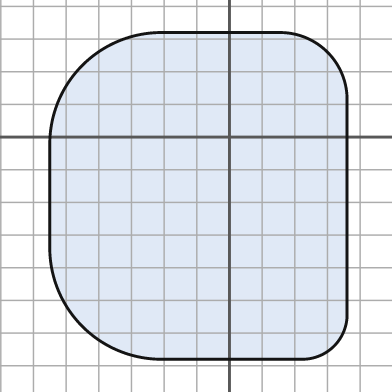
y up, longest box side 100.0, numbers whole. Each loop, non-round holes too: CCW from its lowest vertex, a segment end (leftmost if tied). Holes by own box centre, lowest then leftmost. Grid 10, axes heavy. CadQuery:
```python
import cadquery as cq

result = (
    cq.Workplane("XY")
    .moveTo(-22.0, -68.0)
    .lineTo(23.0, -68.0)
    .threePointArc((32.0, -64.0), (36.0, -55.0))
    .lineTo(36.0, 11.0)
    .threePointArc((30.0, 26.0), (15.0, 32.0))
    .lineTo(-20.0, 32.0)
    .threePointArc((-45.0, 22.0), (-55.0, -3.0))
    .lineTo(-55.0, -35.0)
    .threePointArc((-45.0, -58.0), (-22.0, -68.0))
    .close()
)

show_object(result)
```